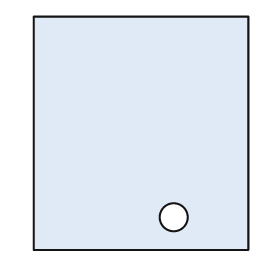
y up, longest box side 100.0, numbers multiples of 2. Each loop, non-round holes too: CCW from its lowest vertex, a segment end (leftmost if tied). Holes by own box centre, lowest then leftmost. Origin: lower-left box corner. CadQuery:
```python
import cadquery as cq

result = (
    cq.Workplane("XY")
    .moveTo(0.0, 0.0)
    .lineTo(92.0, 0.0)
    .lineTo(92.0, 100.0)
    .lineTo(0.0, 100.0)
    .close()
    .moveTo(60.0, 14.0)
    .circle(6.0)
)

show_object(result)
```